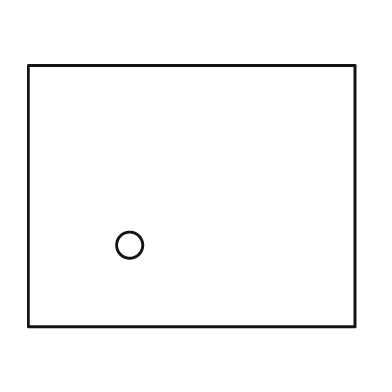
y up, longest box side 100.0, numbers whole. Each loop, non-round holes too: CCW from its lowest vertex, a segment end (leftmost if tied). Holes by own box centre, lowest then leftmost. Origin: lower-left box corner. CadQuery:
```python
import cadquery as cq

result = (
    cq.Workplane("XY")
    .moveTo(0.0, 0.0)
    .lineTo(100.0, 0.0)
    .lineTo(100.0, 80.0)
    .lineTo(0.0, 80.0)
    .close()
    .moveTo(31.0, 25.0)
    .circle(4.0)
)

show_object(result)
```